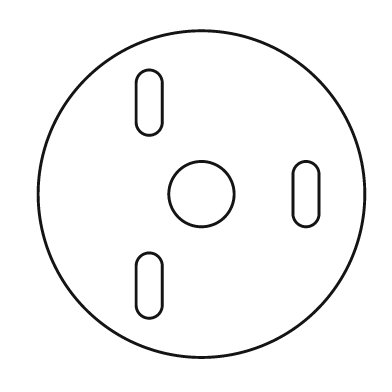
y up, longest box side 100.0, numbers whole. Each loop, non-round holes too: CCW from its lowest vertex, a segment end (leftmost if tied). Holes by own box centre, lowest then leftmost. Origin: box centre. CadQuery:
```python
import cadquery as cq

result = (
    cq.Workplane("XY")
    .moveTo(0.0, 0.0)
    .circle(50.0)
    .moveTo(-20.0, -34.0)
    .threePointArc((-16.0, -38.0), (-12.0, -34.0))
    .lineTo(-12.0, -22.0)
    .threePointArc((-16.0, -18.0), (-20.0, -22.0))
    .close()
    .moveTo(0.0, 0.0)
    .circle(10.0)
    .moveTo(28.0, -6.0)
    .threePointArc((32.0, -10.0), (36.0, -6.0))
    .lineTo(36.0, 6.0)
    .threePointArc((32.0, 10.0), (28.0, 6.0))
    .close()
    .moveTo(-20.0, 22.0)
    .threePointArc((-16.0, 18.0), (-12.0, 22.0))
    .lineTo(-12.0, 34.0)
    .threePointArc((-16.0, 38.0), (-20.0, 34.0))
    .close()
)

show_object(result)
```